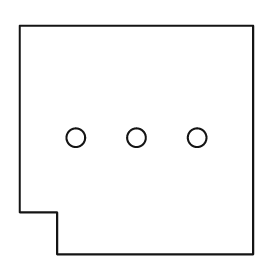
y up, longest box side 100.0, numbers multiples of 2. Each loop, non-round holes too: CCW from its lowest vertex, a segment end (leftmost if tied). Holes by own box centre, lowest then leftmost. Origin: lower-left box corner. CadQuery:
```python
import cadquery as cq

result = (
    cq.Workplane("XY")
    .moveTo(16.0, 0.0)
    .lineTo(100.0, 0.0)
    .lineTo(100.0, 98.0)
    .lineTo(0.0, 98.0)
    .lineTo(0.0, 18.0)
    .lineTo(16.0, 18.0)
    .close()
    .moveTo(24.0, 50.0)
    .circle(4.0)
    .moveTo(50.0, 50.0)
    .circle(4.0)
    .moveTo(76.0, 50.0)
    .circle(4.0)
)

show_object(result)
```